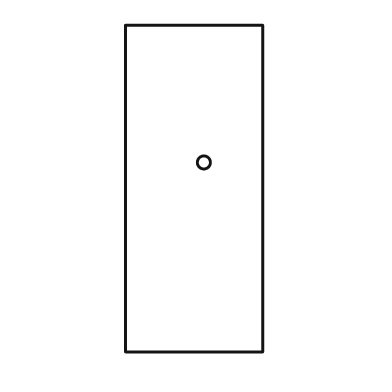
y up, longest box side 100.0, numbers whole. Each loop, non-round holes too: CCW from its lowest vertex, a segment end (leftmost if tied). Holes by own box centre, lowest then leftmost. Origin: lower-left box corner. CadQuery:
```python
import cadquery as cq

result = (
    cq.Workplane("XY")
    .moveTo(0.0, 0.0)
    .lineTo(42.0, 0.0)
    .lineTo(42.0, 100.0)
    .lineTo(0.0, 100.0)
    .close()
    .moveTo(24.0, 58.0)
    .circle(2.0)
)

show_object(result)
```